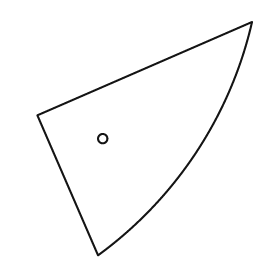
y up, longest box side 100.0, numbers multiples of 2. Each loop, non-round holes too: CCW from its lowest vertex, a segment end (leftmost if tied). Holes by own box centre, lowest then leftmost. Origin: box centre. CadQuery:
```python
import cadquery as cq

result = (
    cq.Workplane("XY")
    .moveTo(-20.0, -50.0)
    .threePointArc((22.0, -6.0), (46.0, 50.0))
    .lineTo(-46.0, 10.0)
    .close()
    .moveTo(-18.0, 0.0)
    .circle(2.0)
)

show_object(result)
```